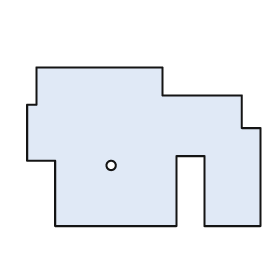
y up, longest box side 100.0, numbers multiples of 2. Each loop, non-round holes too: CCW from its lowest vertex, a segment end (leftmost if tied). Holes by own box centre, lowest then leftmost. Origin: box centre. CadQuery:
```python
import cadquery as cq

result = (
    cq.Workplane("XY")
    .moveTo(-38.0, -34.0)
    .lineTo(14.0, -34.0)
    .lineTo(14.0, -4.0)
    .lineTo(26.0, -4.0)
    .lineTo(26.0, -34.0)
    .lineTo(50.0, -34.0)
    .lineTo(50.0, 8.0)
    .lineTo(42.0, 8.0)
    .lineTo(42.0, 22.0)
    .lineTo(8.0, 22.0)
    .lineTo(8.0, 34.0)
    .lineTo(-46.0, 34.0)
    .lineTo(-46.0, 18.0)
    .lineTo(-50.0, 18.0)
    .lineTo(-50.0, -6.0)
    .lineTo(-38.0, -6.0)
    .close()
    .moveTo(-14.0, -8.0)
    .circle(2.0)
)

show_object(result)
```